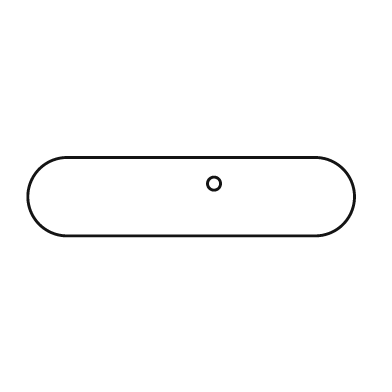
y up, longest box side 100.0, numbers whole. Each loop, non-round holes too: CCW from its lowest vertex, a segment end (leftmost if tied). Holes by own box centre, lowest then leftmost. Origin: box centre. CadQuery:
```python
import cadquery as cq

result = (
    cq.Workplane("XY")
    .moveTo(-38.0, -12.0)
    .lineTo(38.0, -12.0)
    .threePointArc((50.0, 0.0), (38.0, 12.0))
    .lineTo(-38.0, 12.0)
    .threePointArc((-50.0, 0.0), (-38.0, -12.0))
    .close()
    .moveTo(7.0, 4.0)
    .circle(2.0)
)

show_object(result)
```